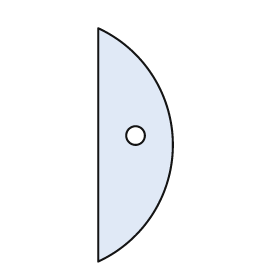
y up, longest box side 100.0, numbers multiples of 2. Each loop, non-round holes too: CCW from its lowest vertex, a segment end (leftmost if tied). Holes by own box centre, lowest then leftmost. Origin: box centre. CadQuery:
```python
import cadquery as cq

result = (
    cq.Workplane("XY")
    .moveTo(-16.0, -50.0)
    .threePointArc((16.0, 0.0), (-16.0, 50.0))
    .close()
    .moveTo(0.0, 4.0)
    .circle(4.0)
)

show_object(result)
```